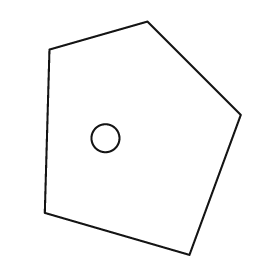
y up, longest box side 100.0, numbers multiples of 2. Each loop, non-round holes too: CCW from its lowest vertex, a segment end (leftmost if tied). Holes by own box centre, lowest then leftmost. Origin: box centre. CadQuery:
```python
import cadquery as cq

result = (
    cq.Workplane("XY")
    .moveTo(20.0, -50.0)
    .lineTo(42.0, 10.0)
    .lineTo(2.0, 50.0)
    .lineTo(-40.0, 38.0)
    .lineTo(-42.0, -32.0)
    .close()
    .moveTo(-16.0, 0.0)
    .circle(6.0)
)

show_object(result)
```